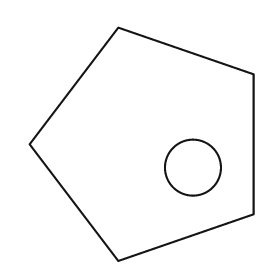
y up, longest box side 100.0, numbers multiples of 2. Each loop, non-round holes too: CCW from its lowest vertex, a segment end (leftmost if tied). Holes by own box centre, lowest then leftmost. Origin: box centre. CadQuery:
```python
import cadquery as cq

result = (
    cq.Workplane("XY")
    .moveTo(-10.0, -50.0)
    .lineTo(48.0, -30.0)
    .lineTo(48.0, 30.0)
    .lineTo(-10.0, 50.0)
    .lineTo(-48.0, 0.0)
    .close()
    .moveTo(22.0, -10.0)
    .circle(12.0)
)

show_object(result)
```